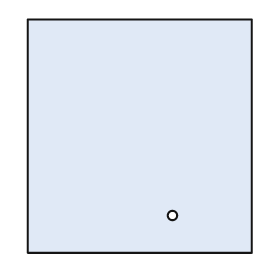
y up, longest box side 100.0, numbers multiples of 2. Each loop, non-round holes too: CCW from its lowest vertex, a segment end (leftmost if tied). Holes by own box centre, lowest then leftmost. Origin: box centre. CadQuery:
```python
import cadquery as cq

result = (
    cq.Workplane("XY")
    .moveTo(-48.0, -50.0)
    .lineTo(48.0, -50.0)
    .lineTo(48.0, 50.0)
    .lineTo(-48.0, 50.0)
    .close()
    .moveTo(14.0, -34.0)
    .circle(2.0)
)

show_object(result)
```